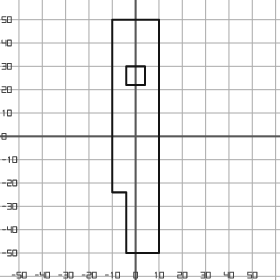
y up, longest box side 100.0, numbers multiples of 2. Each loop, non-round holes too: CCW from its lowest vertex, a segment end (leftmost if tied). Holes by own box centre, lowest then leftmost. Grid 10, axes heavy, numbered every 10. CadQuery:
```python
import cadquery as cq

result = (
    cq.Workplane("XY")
    .moveTo(-4.0, -50.0)
    .lineTo(10.0, -50.0)
    .lineTo(10.0, 50.0)
    .lineTo(-10.0, 50.0)
    .lineTo(-10.0, -24.0)
    .lineTo(-4.0, -24.0)
    .close()
    .moveTo(-4.0, 22.0)
    .lineTo(4.0, 22.0)
    .lineTo(4.0, 30.0)
    .lineTo(-4.0, 30.0)
    .close()
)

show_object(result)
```